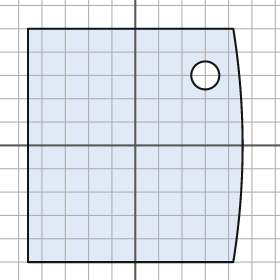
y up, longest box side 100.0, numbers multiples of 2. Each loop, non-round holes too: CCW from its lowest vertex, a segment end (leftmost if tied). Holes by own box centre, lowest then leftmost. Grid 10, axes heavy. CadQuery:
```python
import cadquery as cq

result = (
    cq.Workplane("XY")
    .moveTo(-46.0, -50.0)
    .lineTo(42.0, -50.0)
    .threePointArc((46.0, 0.0), (42.0, 50.0))
    .lineTo(-46.0, 50.0)
    .close()
    .moveTo(30.0, 30.0)
    .circle(6.0)
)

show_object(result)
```